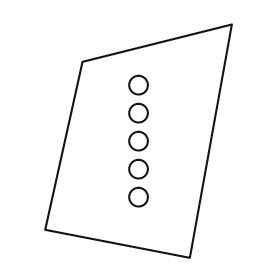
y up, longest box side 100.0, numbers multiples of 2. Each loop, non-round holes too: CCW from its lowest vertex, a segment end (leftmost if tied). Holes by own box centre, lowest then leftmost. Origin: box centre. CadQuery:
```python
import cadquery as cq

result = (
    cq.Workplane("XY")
    .moveTo(22.0, -50.0)
    .lineTo(40.0, 50.0)
    .lineTo(-24.0, 34.0)
    .lineTo(-40.0, -38.0)
    .close()
    .moveTo(0.0, -24.0)
    .circle(4.0)
    .moveTo(0.0, -12.0)
    .circle(4.0)
    .moveTo(0.0, 0.0)
    .circle(4.0)
    .moveTo(0.0, 12.0)
    .circle(4.0)
    .moveTo(0.0, 24.0)
    .circle(4.0)
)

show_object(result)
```